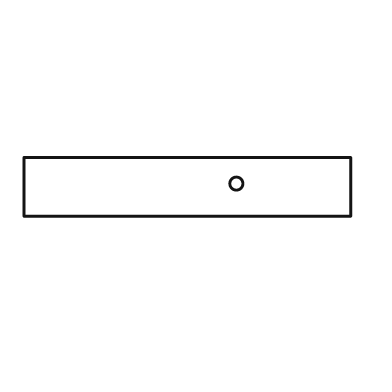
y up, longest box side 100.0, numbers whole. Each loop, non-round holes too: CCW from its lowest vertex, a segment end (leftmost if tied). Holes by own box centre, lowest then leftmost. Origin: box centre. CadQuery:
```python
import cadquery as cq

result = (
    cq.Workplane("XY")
    .moveTo(-50.0, -9.0)
    .lineTo(50.0, -9.0)
    .lineTo(50.0, 9.0)
    .lineTo(-50.0, 9.0)
    .close()
    .moveTo(15.0, 1.0)
    .circle(2.0)
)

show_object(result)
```